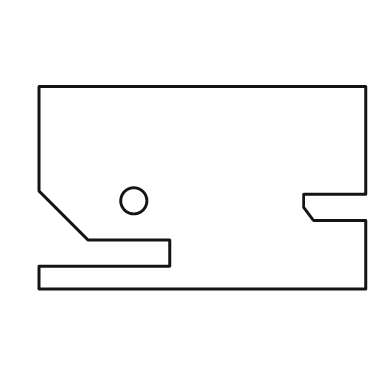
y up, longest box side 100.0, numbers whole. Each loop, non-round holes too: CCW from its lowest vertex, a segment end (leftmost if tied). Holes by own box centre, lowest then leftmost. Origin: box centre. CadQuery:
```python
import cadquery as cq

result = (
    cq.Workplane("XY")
    .moveTo(-50.0, -31.0)
    .lineTo(50.0, -31.0)
    .lineTo(50.0, -10.0)
    .lineTo(34.0, -10.0)
    .lineTo(31.0, -6.0)
    .lineTo(31.0, -2.0)
    .lineTo(50.0, -2.0)
    .lineTo(50.0, 31.0)
    .lineTo(-50.0, 31.0)
    .lineTo(-50.0, -1.0)
    .lineTo(-35.0, -16.0)
    .lineTo(-10.0, -16.0)
    .lineTo(-10.0, -24.0)
    .lineTo(-50.0, -24.0)
    .close()
    .moveTo(-21.0, -4.0)
    .circle(4.0)
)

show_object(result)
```